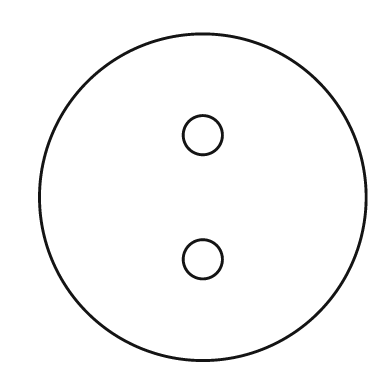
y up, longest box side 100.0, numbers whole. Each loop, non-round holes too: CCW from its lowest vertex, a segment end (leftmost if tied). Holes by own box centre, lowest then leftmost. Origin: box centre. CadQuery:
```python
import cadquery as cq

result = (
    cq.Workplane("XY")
    .moveTo(0.0, 0.0)
    .circle(50.0)
    .moveTo(0.0, -19.0)
    .circle(6.0)
    .moveTo(0.0, 19.0)
    .circle(6.0)
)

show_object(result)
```